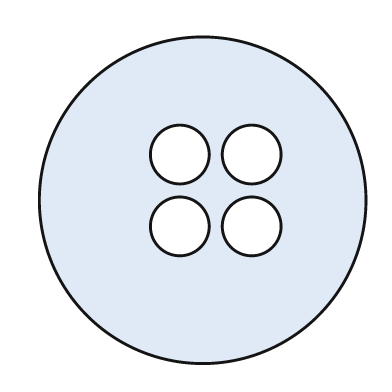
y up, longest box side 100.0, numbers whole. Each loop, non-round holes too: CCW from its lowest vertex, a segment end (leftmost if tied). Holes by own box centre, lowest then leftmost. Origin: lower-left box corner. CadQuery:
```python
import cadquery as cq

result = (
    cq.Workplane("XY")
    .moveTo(50.0, 50.0)
    .circle(50.0)
    .moveTo(43.0, 42.0)
    .circle(9.0)
    .moveTo(65.0, 42.0)
    .circle(9.0)
    .moveTo(43.0, 64.0)
    .circle(9.0)
    .moveTo(65.0, 64.0)
    .circle(9.0)
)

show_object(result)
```